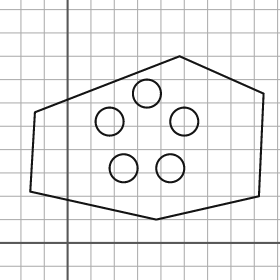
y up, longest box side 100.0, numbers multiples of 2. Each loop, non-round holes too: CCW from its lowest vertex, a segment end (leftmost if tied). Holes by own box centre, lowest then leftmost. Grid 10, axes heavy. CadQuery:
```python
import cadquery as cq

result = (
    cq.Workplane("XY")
    .moveTo(38.0, 10.0)
    .lineTo(82.0, 20.0)
    .lineTo(84.0, 64.0)
    .lineTo(48.0, 80.0)
    .lineTo(-14.0, 56.0)
    .lineTo(-16.0, 22.0)
    .close()
    .moveTo(24.0, 32.0)
    .circle(6.0)
    .moveTo(44.0, 32.0)
    .circle(6.0)
    .moveTo(18.0, 52.0)
    .circle(6.0)
    .moveTo(50.0, 52.0)
    .circle(6.0)
    .moveTo(34.0, 64.0)
    .circle(6.0)
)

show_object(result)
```